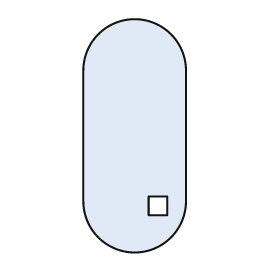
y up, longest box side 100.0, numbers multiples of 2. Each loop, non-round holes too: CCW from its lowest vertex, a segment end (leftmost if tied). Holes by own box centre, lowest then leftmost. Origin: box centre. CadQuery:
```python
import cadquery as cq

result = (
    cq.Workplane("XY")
    .moveTo(-22.0, -28.0)
    .threePointArc((0.0, -50.0), (22.0, -28.0))
    .lineTo(22.0, 28.0)
    .threePointArc((0.0, 50.0), (-22.0, 28.0))
    .close()
    .moveTo(6.0, -34.0)
    .lineTo(14.0, -34.0)
    .lineTo(14.0, -26.0)
    .lineTo(6.0, -26.0)
    .close()
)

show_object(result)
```